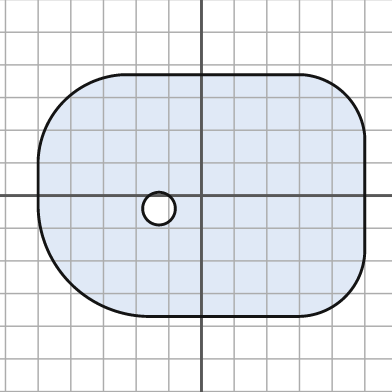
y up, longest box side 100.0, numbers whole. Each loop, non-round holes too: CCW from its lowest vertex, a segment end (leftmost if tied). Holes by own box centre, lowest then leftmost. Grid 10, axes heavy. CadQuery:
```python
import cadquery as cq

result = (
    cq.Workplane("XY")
    .moveTo(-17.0, -37.0)
    .lineTo(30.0, -37.0)
    .threePointArc((44.0, -31.0), (50.0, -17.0))
    .lineTo(50.0, 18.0)
    .threePointArc((44.0, 31.0), (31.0, 37.0))
    .lineTo(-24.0, 37.0)
    .threePointArc((-42.0, 29.0), (-50.0, 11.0))
    .lineTo(-50.0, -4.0)
    .threePointArc((-40.0, -27.0), (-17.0, -37.0))
    .close()
    .moveTo(-13.0, -4.0)
    .circle(5.0)
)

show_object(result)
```